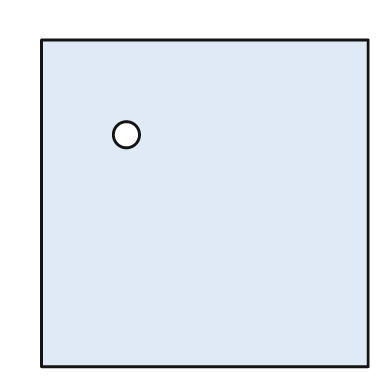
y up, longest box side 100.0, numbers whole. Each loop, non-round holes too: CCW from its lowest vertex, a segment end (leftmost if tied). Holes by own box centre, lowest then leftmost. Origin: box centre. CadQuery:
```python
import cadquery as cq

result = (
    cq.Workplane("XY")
    .moveTo(-50.0, -50.0)
    .lineTo(50.0, -50.0)
    .lineTo(50.0, 50.0)
    .lineTo(-50.0, 50.0)
    .close()
    .moveTo(-24.0, 21.0)
    .circle(4.0)
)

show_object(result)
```